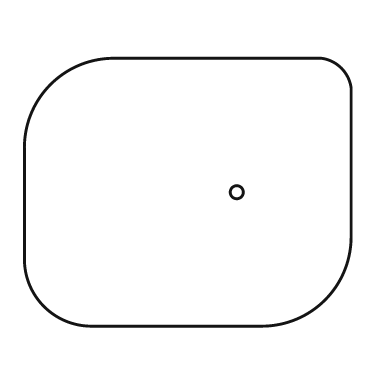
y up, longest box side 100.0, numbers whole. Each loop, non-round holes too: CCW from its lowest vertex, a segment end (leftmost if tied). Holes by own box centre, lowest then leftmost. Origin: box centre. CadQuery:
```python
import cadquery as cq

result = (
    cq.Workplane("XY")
    .moveTo(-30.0, -41.0)
    .lineTo(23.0, -41.0)
    .threePointArc((42.0, -33.0), (50.0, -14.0))
    .lineTo(50.0, 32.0)
    .threePointArc((47.0, 38.0), (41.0, 41.0))
    .lineTo(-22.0, 41.0)
    .threePointArc((-42.0, 33.0), (-50.0, 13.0))
    .lineTo(-50.0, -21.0)
    .threePointArc((-44.0, -35.0), (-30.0, -41.0))
    .close()
    .moveTo(15.0, 0.0)
    .circle(2.0)
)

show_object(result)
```